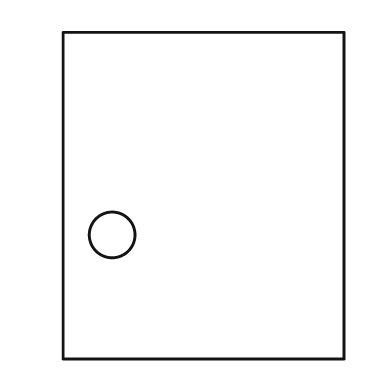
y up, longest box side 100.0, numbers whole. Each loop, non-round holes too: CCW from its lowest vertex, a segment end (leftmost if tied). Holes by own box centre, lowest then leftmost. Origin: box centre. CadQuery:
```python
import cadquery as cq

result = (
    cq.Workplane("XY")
    .moveTo(-43.0, -50.0)
    .lineTo(43.0, -50.0)
    .lineTo(43.0, 50.0)
    .lineTo(-43.0, 50.0)
    .close()
    .moveTo(-28.0, -12.0)
    .circle(7.0)
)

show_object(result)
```